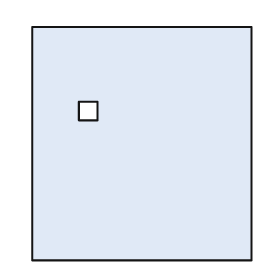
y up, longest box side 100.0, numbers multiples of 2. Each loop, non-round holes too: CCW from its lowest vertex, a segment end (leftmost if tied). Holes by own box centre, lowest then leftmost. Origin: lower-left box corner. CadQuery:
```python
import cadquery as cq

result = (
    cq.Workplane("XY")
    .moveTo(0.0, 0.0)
    .lineTo(94.0, 0.0)
    .lineTo(94.0, 100.0)
    .lineTo(0.0, 100.0)
    .close()
    .moveTo(20.0, 60.0)
    .lineTo(28.0, 60.0)
    .lineTo(28.0, 68.0)
    .lineTo(20.0, 68.0)
    .close()
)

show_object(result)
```